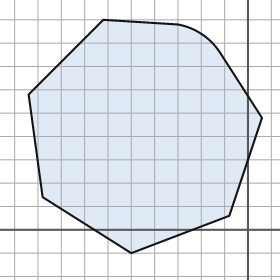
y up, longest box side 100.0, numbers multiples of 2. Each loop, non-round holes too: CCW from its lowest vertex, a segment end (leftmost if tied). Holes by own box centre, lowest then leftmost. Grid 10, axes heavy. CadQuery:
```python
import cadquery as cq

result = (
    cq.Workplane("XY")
    .moveTo(-50.0, -10.0)
    .lineTo(-8.0, 6.0)
    .lineTo(6.0, 48.0)
    .lineTo(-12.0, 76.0)
    .threePointArc((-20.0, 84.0), (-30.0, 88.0))
    .lineTo(-62.0, 90.0)
    .lineTo(-94.0, 58.0)
    .lineTo(-88.0, 14.0)
    .close()
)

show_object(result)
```